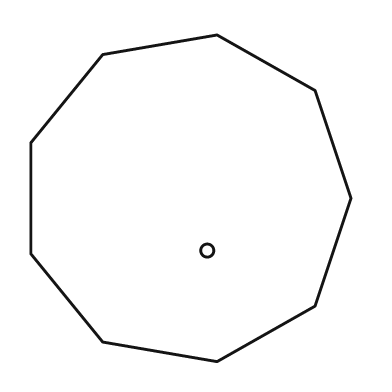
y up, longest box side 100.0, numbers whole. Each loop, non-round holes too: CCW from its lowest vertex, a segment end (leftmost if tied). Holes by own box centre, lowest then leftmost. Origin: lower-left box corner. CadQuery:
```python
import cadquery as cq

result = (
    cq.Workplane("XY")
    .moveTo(57.0, 0.0)
    .lineTo(87.0, 17.0)
    .lineTo(98.0, 50.0)
    .lineTo(87.0, 83.0)
    .lineTo(57.0, 100.0)
    .lineTo(22.0, 94.0)
    .lineTo(0.0, 67.0)
    .lineTo(0.0, 33.0)
    .lineTo(22.0, 6.0)
    .close()
    .moveTo(54.0, 34.0)
    .circle(2.0)
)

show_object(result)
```